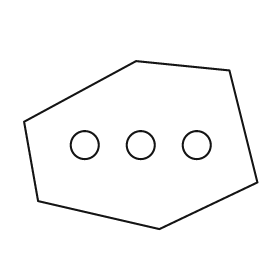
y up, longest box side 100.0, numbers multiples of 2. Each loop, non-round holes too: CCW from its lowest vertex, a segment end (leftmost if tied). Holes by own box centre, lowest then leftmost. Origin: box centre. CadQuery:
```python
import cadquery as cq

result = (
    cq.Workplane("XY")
    .moveTo(8.0, -36.0)
    .lineTo(50.0, -16.0)
    .lineTo(38.0, 32.0)
    .lineTo(-2.0, 36.0)
    .lineTo(-50.0, 10.0)
    .lineTo(-44.0, -24.0)
    .close()
    .moveTo(-24.0, 0.0)
    .circle(6.0)
    .moveTo(0.0, 0.0)
    .circle(6.0)
    .moveTo(24.0, 0.0)
    .circle(6.0)
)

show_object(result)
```